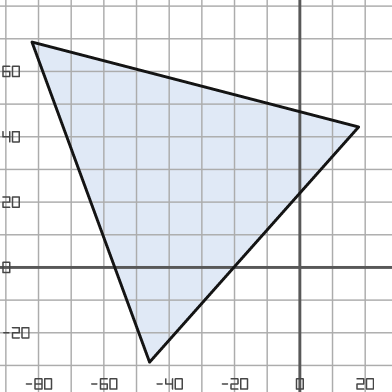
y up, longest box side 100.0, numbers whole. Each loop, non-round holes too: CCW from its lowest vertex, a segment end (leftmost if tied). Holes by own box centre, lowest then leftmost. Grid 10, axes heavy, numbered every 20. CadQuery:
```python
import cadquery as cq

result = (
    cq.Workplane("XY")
    .moveTo(-46.0, -29.0)
    .lineTo(18.0, 43.0)
    .lineTo(-82.0, 69.0)
    .close()
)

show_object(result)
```